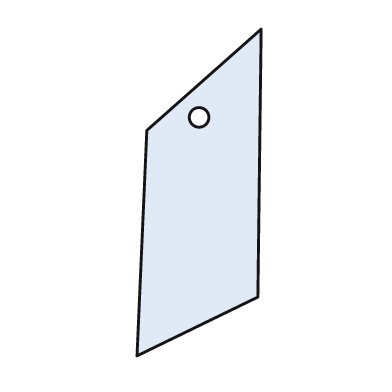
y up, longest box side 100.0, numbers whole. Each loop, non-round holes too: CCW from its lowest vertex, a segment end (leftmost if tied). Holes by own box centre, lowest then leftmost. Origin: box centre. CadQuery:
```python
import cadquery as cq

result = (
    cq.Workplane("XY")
    .moveTo(-19.0, -50.0)
    .lineTo(18.0, -32.0)
    .lineTo(19.0, 50.0)
    .lineTo(-16.0, 19.0)
    .close()
    .moveTo(0.0, 23.0)
    .circle(3.0)
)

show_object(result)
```